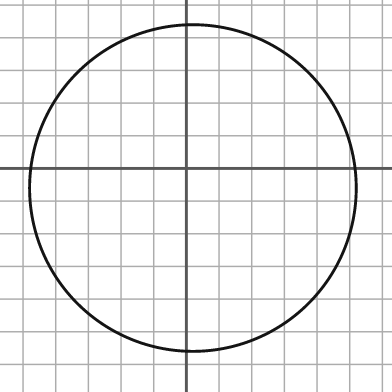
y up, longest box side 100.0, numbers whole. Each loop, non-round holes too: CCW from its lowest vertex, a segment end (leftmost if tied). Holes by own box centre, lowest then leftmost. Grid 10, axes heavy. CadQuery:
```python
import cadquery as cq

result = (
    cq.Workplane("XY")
    .moveTo(2.0, -6.0)
    .circle(50.0)
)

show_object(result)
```